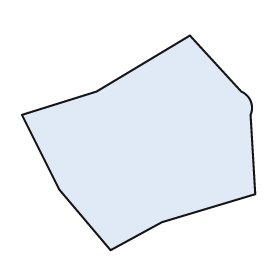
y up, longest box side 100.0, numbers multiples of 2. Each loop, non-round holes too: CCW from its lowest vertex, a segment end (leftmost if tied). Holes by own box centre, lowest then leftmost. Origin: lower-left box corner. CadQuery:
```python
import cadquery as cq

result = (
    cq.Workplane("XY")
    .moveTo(38.0, 0.0)
    .lineTo(60.0, 12.0)
    .lineTo(100.0, 24.0)
    .lineTo(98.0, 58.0)
    .threePointArc((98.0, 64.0), (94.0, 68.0))
    .lineTo(72.0, 92.0)
    .lineTo(32.0, 68.0)
    .lineTo(0.0, 58.0)
    .lineTo(16.0, 26.0)
    .close()
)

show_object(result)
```